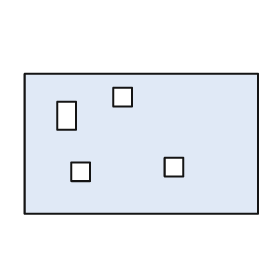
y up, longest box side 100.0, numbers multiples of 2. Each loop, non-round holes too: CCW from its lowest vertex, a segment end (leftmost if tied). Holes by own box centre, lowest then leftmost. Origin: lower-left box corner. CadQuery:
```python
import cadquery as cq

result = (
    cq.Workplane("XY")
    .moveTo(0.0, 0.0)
    .lineTo(100.0, 0.0)
    .lineTo(100.0, 60.0)
    .lineTo(0.0, 60.0)
    .close()
    .moveTo(20.0, 14.0)
    .lineTo(28.0, 14.0)
    .lineTo(28.0, 22.0)
    .lineTo(20.0, 22.0)
    .close()
    .moveTo(60.0, 16.0)
    .lineTo(68.0, 16.0)
    .lineTo(68.0, 24.0)
    .lineTo(60.0, 24.0)
    .close()
    .moveTo(14.0, 36.0)
    .lineTo(22.0, 36.0)
    .lineTo(22.0, 48.0)
    .lineTo(14.0, 48.0)
    .close()
    .moveTo(38.0, 46.0)
    .lineTo(46.0, 46.0)
    .lineTo(46.0, 54.0)
    .lineTo(38.0, 54.0)
    .close()
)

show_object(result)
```